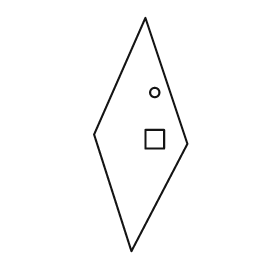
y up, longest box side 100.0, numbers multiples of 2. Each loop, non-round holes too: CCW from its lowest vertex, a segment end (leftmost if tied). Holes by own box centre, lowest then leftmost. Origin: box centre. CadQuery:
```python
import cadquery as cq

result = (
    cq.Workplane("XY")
    .moveTo(-4.0, -50.0)
    .lineTo(20.0, -4.0)
    .lineTo(2.0, 50.0)
    .lineTo(-20.0, 0.0)
    .close()
    .moveTo(2.0, -6.0)
    .lineTo(10.0, -6.0)
    .lineTo(10.0, 2.0)
    .lineTo(2.0, 2.0)
    .close()
    .moveTo(6.0, 18.0)
    .circle(2.0)
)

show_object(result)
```